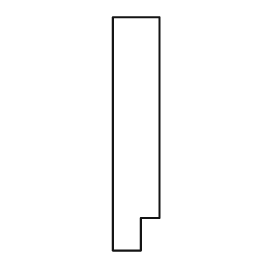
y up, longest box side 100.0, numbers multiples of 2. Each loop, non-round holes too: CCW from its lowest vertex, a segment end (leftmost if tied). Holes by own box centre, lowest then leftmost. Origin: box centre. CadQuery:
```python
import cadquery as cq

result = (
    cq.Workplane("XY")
    .moveTo(-10.0, -50.0)
    .lineTo(2.0, -50.0)
    .lineTo(2.0, -36.0)
    .lineTo(10.0, -36.0)
    .lineTo(10.0, 50.0)
    .lineTo(-10.0, 50.0)
    .close()
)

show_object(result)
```